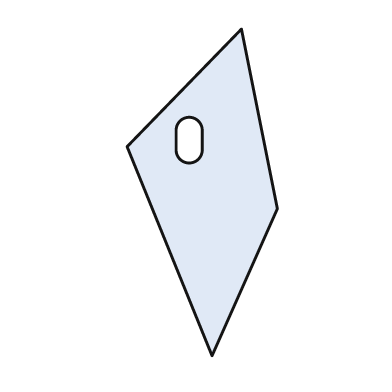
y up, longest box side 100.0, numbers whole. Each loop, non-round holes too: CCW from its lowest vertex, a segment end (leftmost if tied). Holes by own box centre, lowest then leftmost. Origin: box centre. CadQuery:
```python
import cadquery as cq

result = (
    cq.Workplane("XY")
    .moveTo(3.0, -50.0)
    .lineTo(23.0, -5.0)
    .lineTo(12.0, 50.0)
    .lineTo(-23.0, 14.0)
    .close()
    .moveTo(-8.0, 13.0)
    .threePointArc((-4.0, 9.0), (0.0, 13.0))
    .lineTo(0.0, 19.0)
    .threePointArc((-4.0, 23.0), (-8.0, 19.0))
    .close()
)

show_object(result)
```